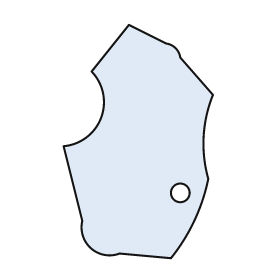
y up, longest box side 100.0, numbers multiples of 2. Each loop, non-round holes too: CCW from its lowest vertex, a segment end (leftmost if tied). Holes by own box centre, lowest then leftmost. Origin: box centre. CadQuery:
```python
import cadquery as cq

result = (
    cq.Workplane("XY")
    .moveTo(14.0, -50.0)
    .threePointArc((24.0, -34.0), (30.0, -16.0))
    .threePointArc((28.0, 2.0), (32.0, 20.0))
    .lineTo(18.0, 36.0)
    .threePointArc((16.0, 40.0), (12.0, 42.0))
    .lineTo(-4.0, 50.0)
    .lineTo(-20.0, 30.0)
    .threePointArc((-16.0, 10.0), (-32.0, -2.0))
    .lineTo(-24.0, -34.0)
    .threePointArc((-20.0, -46.0), (-8.0, -48.0))
    .close()
    .moveTo(18.0, -22.0)
    .circle(4.0)
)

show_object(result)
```